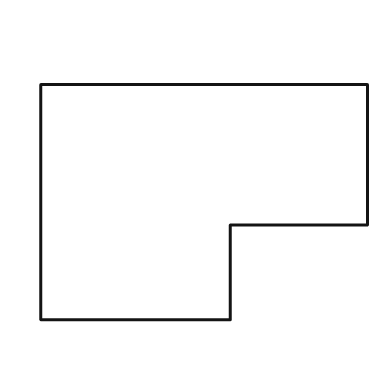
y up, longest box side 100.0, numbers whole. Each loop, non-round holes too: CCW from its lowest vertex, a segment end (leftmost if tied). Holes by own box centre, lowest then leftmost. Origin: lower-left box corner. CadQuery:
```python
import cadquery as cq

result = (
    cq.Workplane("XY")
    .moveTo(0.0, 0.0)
    .lineTo(58.0, 0.0)
    .lineTo(58.0, 29.0)
    .lineTo(100.0, 29.0)
    .lineTo(100.0, 72.0)
    .lineTo(0.0, 72.0)
    .close()
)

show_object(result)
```